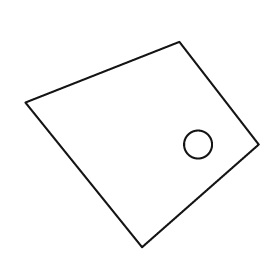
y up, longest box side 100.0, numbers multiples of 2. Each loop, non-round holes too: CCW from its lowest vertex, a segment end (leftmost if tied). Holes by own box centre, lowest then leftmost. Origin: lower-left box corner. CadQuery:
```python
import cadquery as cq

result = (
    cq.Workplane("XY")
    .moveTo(50.0, 0.0)
    .lineTo(100.0, 44.0)
    .lineTo(66.0, 88.0)
    .lineTo(0.0, 62.0)
    .close()
    .moveTo(74.0, 44.0)
    .circle(6.0)
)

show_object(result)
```